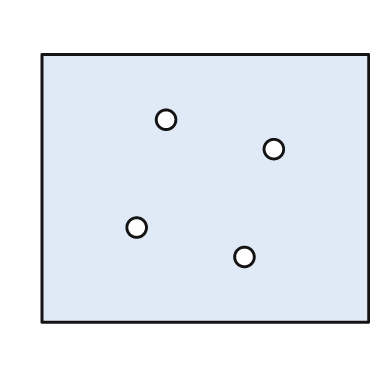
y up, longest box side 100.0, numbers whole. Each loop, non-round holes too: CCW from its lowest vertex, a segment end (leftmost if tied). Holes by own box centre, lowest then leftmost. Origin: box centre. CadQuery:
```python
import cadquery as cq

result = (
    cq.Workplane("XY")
    .moveTo(-50.0, -41.0)
    .lineTo(50.0, -41.0)
    .lineTo(50.0, 41.0)
    .lineTo(-50.0, 41.0)
    .close()
    .moveTo(12.0, -21.0)
    .circle(3.0)
    .moveTo(-21.0, -12.0)
    .circle(3.0)
    .moveTo(21.0, 12.0)
    .circle(3.0)
    .moveTo(-12.0, 21.0)
    .circle(3.0)
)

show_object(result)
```